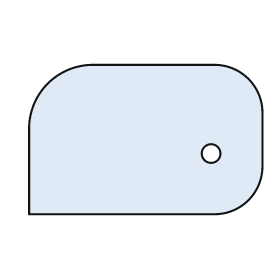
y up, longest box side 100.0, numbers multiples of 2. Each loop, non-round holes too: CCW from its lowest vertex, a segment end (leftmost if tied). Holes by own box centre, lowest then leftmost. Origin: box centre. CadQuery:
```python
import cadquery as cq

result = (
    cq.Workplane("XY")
    .moveTo(-50.0, -32.0)
    .lineTo(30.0, -32.0)
    .threePointArc((44.0, -26.0), (50.0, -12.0))
    .lineTo(50.0, 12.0)
    .threePointArc((44.0, 26.0), (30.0, 32.0))
    .lineTo(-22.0, 32.0)
    .threePointArc((-42.0, 24.0), (-50.0, 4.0))
    .close()
    .moveTo(28.0, -6.0)
    .circle(4.0)
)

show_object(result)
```